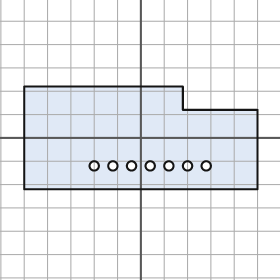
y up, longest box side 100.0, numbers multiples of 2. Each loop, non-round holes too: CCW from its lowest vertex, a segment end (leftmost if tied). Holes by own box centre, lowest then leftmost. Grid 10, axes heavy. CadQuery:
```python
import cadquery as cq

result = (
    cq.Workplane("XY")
    .moveTo(-50.0, -22.0)
    .lineTo(50.0, -22.0)
    .lineTo(50.0, 12.0)
    .lineTo(18.0, 12.0)
    .lineTo(18.0, 22.0)
    .lineTo(-50.0, 22.0)
    .close()
    .moveTo(-20.0, -12.0)
    .circle(2.0)
    .moveTo(-12.0, -12.0)
    .circle(2.0)
    .moveTo(-4.0, -12.0)
    .circle(2.0)
    .moveTo(4.0, -12.0)
    .circle(2.0)
    .moveTo(12.0, -12.0)
    .circle(2.0)
    .moveTo(20.0, -12.0)
    .circle(2.0)
    .moveTo(28.0, -12.0)
    .circle(2.0)
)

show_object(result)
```